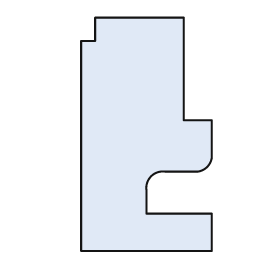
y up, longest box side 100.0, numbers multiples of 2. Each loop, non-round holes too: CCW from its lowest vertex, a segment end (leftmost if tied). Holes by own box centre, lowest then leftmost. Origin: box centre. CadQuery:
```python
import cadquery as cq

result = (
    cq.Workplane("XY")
    .moveTo(-28.0, -50.0)
    .lineTo(28.0, -50.0)
    .lineTo(28.0, -34.0)
    .lineTo(0.0, -34.0)
    .lineTo(0.0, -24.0)
    .threePointArc((2.0, -18.0), (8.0, -16.0))
    .lineTo(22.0, -16.0)
    .threePointArc((26.0, -14.0), (28.0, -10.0))
    .lineTo(28.0, 6.0)
    .lineTo(16.0, 6.0)
    .lineTo(16.0, 50.0)
    .lineTo(-22.0, 50.0)
    .lineTo(-22.0, 40.0)
    .lineTo(-28.0, 40.0)
    .close()
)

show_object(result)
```